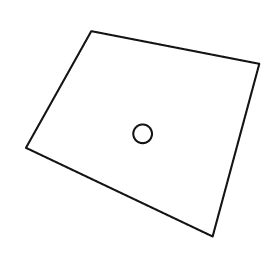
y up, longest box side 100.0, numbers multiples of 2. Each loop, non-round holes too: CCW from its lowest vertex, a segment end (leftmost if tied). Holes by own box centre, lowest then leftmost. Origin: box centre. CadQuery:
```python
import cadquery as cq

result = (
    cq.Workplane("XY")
    .moveTo(30.0, -44.0)
    .lineTo(50.0, 30.0)
    .lineTo(-22.0, 44.0)
    .lineTo(-50.0, -6.0)
    .close()
    .moveTo(0.0, 0.0)
    .circle(4.0)
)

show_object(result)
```